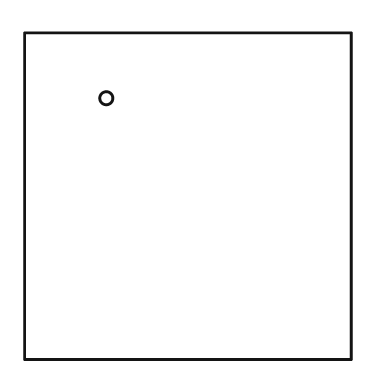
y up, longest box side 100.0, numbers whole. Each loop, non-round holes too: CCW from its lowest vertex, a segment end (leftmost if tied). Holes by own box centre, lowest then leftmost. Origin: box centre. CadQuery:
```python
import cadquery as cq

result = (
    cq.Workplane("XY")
    .moveTo(-50.0, -50.0)
    .lineTo(50.0, -50.0)
    .lineTo(50.0, 50.0)
    .lineTo(-50.0, 50.0)
    .close()
    .moveTo(-25.0, 30.0)
    .circle(2.0)
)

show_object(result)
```